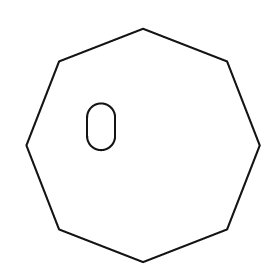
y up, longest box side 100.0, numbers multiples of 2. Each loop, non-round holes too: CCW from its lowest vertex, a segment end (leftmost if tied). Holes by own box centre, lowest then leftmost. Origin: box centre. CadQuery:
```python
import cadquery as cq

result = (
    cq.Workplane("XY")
    .moveTo(0.0, -50.0)
    .lineTo(36.0, -36.0)
    .lineTo(50.0, 0.0)
    .lineTo(36.0, 36.0)
    .lineTo(0.0, 50.0)
    .lineTo(-36.0, 36.0)
    .lineTo(-50.0, 0.0)
    .lineTo(-36.0, -36.0)
    .close()
    .moveTo(-24.0, 4.0)
    .threePointArc((-18.0, -2.0), (-12.0, 4.0))
    .lineTo(-12.0, 12.0)
    .threePointArc((-18.0, 18.0), (-24.0, 12.0))
    .close()
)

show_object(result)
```